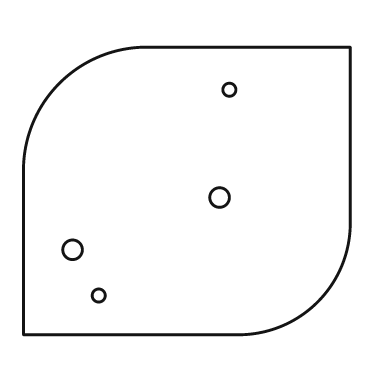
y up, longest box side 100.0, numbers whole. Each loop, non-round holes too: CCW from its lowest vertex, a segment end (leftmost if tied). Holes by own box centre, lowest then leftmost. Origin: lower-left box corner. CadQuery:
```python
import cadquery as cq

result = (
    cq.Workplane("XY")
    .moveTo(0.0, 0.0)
    .lineTo(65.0, 0.0)
    .threePointArc((90.0, 10.0), (100.0, 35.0))
    .lineTo(100.0, 88.0)
    .lineTo(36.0, 88.0)
    .threePointArc((11.0, 77.0), (0.0, 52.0))
    .close()
    .moveTo(23.0, 12.0)
    .circle(2.0)
    .moveTo(15.0, 26.0)
    .circle(3.0)
    .moveTo(60.0, 42.0)
    .circle(3.0)
    .moveTo(63.0, 75.0)
    .circle(2.0)
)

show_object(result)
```